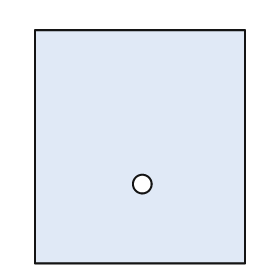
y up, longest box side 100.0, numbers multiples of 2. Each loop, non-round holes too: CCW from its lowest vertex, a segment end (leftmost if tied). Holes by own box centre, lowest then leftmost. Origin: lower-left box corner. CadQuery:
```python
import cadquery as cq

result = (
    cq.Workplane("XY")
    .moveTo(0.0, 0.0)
    .lineTo(90.0, 0.0)
    .lineTo(90.0, 100.0)
    .lineTo(0.0, 100.0)
    .close()
    .moveTo(46.0, 34.0)
    .circle(4.0)
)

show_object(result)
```